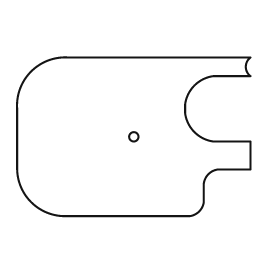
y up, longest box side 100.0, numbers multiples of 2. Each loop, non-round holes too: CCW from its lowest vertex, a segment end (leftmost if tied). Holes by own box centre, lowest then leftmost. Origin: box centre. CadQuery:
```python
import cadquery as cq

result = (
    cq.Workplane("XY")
    .moveTo(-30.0, -34.0)
    .lineTo(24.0, -34.0)
    .threePointArc((28.0, -32.0), (30.0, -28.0))
    .lineTo(30.0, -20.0)
    .threePointArc((32.0, -16.0), (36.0, -14.0))
    .lineTo(50.0, -14.0)
    .lineTo(50.0, -2.0)
    .lineTo(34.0, -2.0)
    .threePointArc((26.0, 2.0), (22.0, 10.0))
    .lineTo(22.0, 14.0)
    .threePointArc((26.0, 22.0), (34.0, 26.0))
    .lineTo(50.0, 26.0)
    .threePointArc((48.0, 30.0), (50.0, 34.0))
    .lineTo(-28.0, 34.0)
    .threePointArc((-44.0, 28.0), (-50.0, 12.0))
    .lineTo(-50.0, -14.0)
    .threePointArc((-44.0, -28.0), (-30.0, -34.0))
    .close()
    .moveTo(0.0, 0.0)
    .circle(2.0)
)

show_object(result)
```